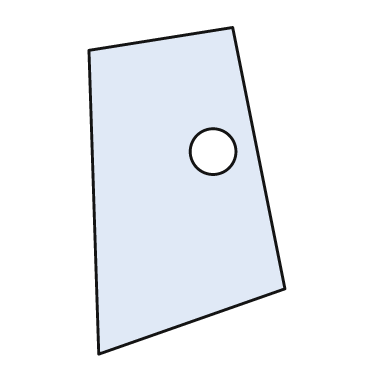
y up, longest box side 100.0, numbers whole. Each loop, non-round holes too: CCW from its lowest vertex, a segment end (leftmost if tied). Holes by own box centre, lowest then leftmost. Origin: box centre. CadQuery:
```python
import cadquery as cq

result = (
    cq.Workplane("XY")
    .moveTo(-27.0, -50.0)
    .lineTo(30.0, -30.0)
    .lineTo(14.0, 50.0)
    .lineTo(-30.0, 43.0)
    .close()
    .moveTo(8.0, 12.0)
    .circle(7.0)
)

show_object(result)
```